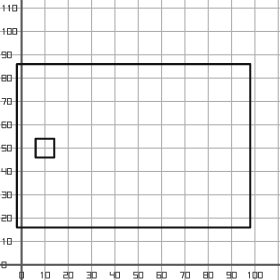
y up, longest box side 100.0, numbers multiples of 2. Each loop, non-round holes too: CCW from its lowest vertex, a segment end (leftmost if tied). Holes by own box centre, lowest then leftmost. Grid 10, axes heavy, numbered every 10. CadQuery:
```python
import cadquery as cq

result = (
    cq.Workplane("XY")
    .moveTo(-2.0, 16.0)
    .lineTo(98.0, 16.0)
    .lineTo(98.0, 86.0)
    .lineTo(-2.0, 86.0)
    .close()
    .moveTo(6.0, 46.0)
    .lineTo(14.0, 46.0)
    .lineTo(14.0, 54.0)
    .lineTo(6.0, 54.0)
    .close()
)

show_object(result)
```